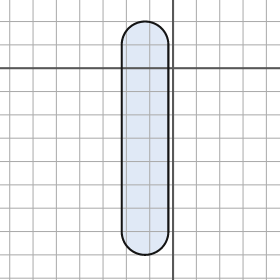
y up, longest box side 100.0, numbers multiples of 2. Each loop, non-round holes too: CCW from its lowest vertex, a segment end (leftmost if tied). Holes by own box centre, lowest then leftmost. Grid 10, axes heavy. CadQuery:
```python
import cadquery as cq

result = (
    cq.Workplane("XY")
    .moveTo(-22.0, -70.0)
    .threePointArc((-12.0, -80.0), (-2.0, -70.0))
    .lineTo(-2.0, 10.0)
    .threePointArc((-12.0, 20.0), (-22.0, 10.0))
    .close()
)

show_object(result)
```